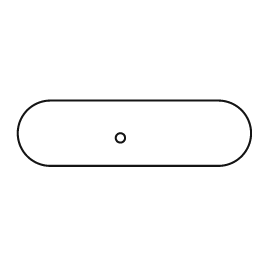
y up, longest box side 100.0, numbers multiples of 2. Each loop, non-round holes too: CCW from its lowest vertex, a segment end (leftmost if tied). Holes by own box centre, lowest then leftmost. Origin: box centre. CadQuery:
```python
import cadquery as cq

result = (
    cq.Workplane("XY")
    .moveTo(-36.0, -14.0)
    .lineTo(36.0, -14.0)
    .threePointArc((50.0, 0.0), (36.0, 14.0))
    .lineTo(-36.0, 14.0)
    .threePointArc((-50.0, 0.0), (-36.0, -14.0))
    .close()
    .moveTo(-6.0, -2.0)
    .circle(2.0)
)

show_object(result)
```